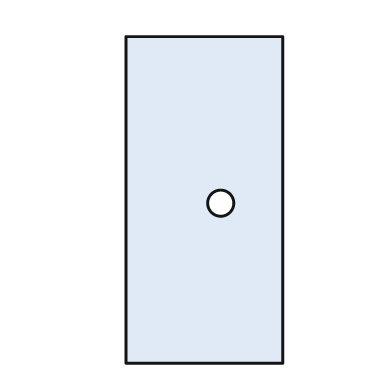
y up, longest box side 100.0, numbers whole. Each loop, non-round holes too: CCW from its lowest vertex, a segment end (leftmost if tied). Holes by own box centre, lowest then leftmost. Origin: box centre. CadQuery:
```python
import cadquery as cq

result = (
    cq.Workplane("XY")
    .moveTo(-24.0, -50.0)
    .lineTo(24.0, -50.0)
    .lineTo(24.0, 50.0)
    .lineTo(-24.0, 50.0)
    .close()
    .moveTo(5.0, -1.0)
    .circle(4.0)
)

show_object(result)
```